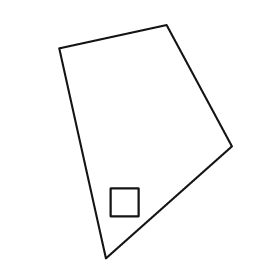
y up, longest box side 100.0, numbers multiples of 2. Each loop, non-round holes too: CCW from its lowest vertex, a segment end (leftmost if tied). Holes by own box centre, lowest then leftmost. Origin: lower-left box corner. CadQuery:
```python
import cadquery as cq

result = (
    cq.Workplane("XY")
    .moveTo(20.0, 0.0)
    .lineTo(74.0, 48.0)
    .lineTo(46.0, 100.0)
    .lineTo(0.0, 90.0)
    .close()
    .moveTo(22.0, 18.0)
    .lineTo(34.0, 18.0)
    .lineTo(34.0, 30.0)
    .lineTo(22.0, 30.0)
    .close()
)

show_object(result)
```